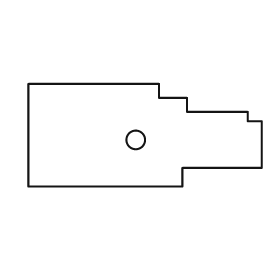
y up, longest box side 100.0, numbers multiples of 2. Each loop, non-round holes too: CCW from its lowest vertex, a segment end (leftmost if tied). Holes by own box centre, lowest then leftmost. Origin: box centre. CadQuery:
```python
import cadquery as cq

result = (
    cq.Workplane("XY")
    .moveTo(-50.0, -22.0)
    .lineTo(16.0, -22.0)
    .lineTo(16.0, -14.0)
    .lineTo(50.0, -14.0)
    .lineTo(50.0, 6.0)
    .lineTo(44.0, 6.0)
    .lineTo(44.0, 10.0)
    .lineTo(18.0, 10.0)
    .lineTo(18.0, 16.0)
    .lineTo(6.0, 16.0)
    .lineTo(6.0, 22.0)
    .lineTo(-50.0, 22.0)
    .close()
    .moveTo(-4.0, -2.0)
    .circle(4.0)
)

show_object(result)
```